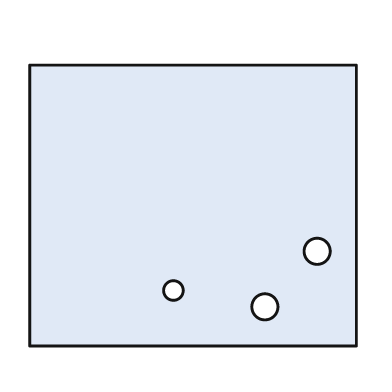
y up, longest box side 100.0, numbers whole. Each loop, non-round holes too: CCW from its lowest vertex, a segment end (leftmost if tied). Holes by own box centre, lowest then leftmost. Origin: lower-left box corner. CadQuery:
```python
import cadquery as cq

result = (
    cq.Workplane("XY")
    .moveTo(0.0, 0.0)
    .lineTo(100.0, 0.0)
    .lineTo(100.0, 86.0)
    .lineTo(0.0, 86.0)
    .close()
    .moveTo(72.0, 12.0)
    .circle(4.0)
    .moveTo(44.0, 17.0)
    .circle(3.0)
    .moveTo(88.0, 29.0)
    .circle(4.0)
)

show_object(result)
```